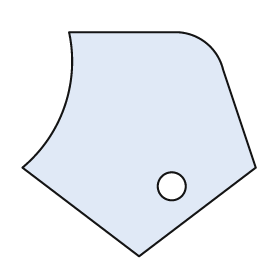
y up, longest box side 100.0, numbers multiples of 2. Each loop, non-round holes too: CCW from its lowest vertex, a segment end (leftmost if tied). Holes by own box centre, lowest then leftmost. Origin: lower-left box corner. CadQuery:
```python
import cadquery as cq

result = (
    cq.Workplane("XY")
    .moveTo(50.0, 0.0)
    .lineTo(100.0, 38.0)
    .lineTo(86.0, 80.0)
    .threePointArc((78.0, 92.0), (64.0, 96.0))
    .lineTo(20.0, 96.0)
    .threePointArc((18.0, 64.0), (0.0, 38.0))
    .close()
    .moveTo(64.0, 30.0)
    .circle(6.0)
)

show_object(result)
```